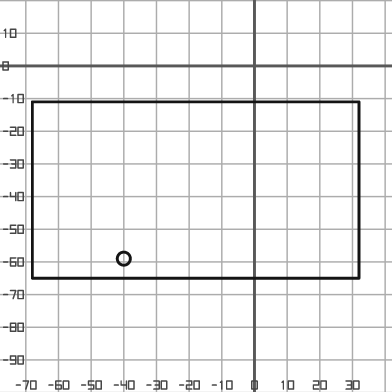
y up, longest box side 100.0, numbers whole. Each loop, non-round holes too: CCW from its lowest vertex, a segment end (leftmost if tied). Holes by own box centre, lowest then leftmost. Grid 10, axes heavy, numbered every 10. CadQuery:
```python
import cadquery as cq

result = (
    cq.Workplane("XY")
    .moveTo(-68.0, -65.0)
    .lineTo(32.0, -65.0)
    .lineTo(32.0, -11.0)
    .lineTo(-68.0, -11.0)
    .close()
    .moveTo(-40.0, -59.0)
    .circle(2.0)
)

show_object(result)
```